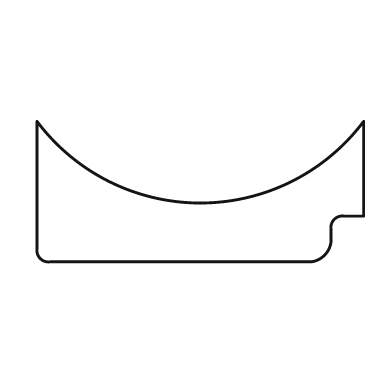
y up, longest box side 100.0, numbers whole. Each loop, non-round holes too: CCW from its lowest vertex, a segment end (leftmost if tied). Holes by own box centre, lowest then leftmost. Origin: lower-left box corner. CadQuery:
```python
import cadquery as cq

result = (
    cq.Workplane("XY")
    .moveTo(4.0, 0.0)
    .lineTo(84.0, 0.0)
    .threePointArc((88.0, 2.0), (90.0, 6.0))
    .lineTo(90.0, 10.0)
    .threePointArc((91.0, 13.0), (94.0, 14.0))
    .lineTo(100.0, 14.0)
    .lineTo(100.0, 43.0)
    .threePointArc((50.0, 18.0), (0.0, 43.0))
    .lineTo(0.0, 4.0)
    .threePointArc((1.0, 1.0), (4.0, 0.0))
    .close()
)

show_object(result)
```